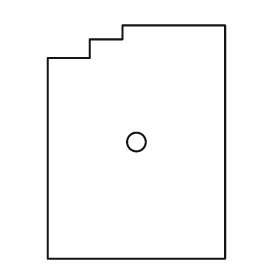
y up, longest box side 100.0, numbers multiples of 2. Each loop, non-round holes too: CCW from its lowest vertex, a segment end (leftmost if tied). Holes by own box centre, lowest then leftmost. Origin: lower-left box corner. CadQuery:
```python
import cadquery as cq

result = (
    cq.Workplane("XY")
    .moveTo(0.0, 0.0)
    .lineTo(76.0, 0.0)
    .lineTo(76.0, 100.0)
    .lineTo(32.0, 100.0)
    .lineTo(32.0, 94.0)
    .lineTo(18.0, 94.0)
    .lineTo(18.0, 86.0)
    .lineTo(0.0, 86.0)
    .close()
    .moveTo(38.0, 50.0)
    .circle(4.0)
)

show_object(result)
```